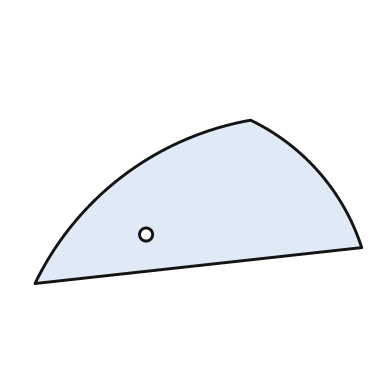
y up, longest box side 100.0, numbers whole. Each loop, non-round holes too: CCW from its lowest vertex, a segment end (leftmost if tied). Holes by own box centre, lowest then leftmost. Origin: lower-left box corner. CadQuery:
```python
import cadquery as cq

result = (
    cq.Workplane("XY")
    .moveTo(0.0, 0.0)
    .lineTo(100.0, 11.0)
    .threePointArc((87.0, 34.0), (66.0, 50.0))
    .threePointArc((27.0, 33.0), (0.0, 0.0))
    .close()
    .moveTo(34.0, 15.0)
    .circle(2.0)
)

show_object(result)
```